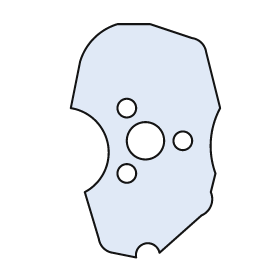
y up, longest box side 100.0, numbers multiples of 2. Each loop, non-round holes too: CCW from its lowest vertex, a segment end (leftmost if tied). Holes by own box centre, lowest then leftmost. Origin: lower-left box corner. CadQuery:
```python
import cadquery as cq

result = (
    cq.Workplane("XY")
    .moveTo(28.0, 0.0)
    .threePointArc((32.0, 6.0), (38.0, 2.0))
    .lineTo(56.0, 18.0)
    .threePointArc((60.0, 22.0), (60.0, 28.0))
    .lineTo(62.0, 36.0)
    .threePointArc((60.0, 50.0), (64.0, 64.0))
    .lineTo(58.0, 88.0)
    .threePointArc((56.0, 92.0), (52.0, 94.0))
    .lineTo(34.0, 100.0)
    .lineTo(20.0, 100.0)
    .threePointArc((10.0, 94.0), (4.0, 84.0))
    .lineTo(0.0, 64.0)
    .threePointArc((16.0, 48.0), (6.0, 28.0))
    .lineTo(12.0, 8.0)
    .threePointArc((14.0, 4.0), (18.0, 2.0))
    .close()
    .moveTo(24.0, 36.0)
    .circle(4.0)
    .moveTo(32.0, 50.0)
    .circle(8.0)
    .moveTo(48.0, 50.0)
    .circle(4.0)
    .moveTo(24.0, 64.0)
    .circle(4.0)
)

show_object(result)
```